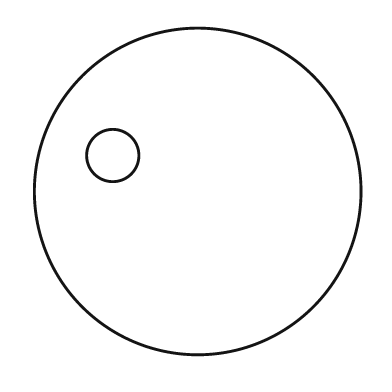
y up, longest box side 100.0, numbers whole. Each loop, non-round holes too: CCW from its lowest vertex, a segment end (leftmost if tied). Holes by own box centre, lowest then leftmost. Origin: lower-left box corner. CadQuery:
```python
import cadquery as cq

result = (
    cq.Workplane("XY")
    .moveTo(50.0, 50.0)
    .circle(50.0)
    .moveTo(24.0, 61.0)
    .circle(8.0)
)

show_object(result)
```